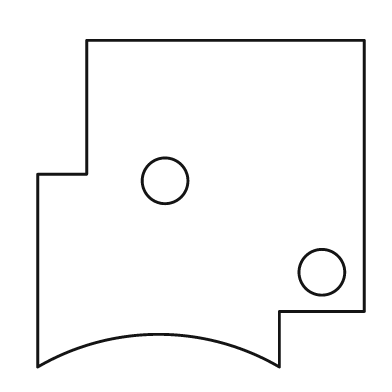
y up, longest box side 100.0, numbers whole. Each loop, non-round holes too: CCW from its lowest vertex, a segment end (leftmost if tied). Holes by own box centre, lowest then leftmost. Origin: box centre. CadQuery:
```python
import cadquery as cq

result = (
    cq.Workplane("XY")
    .moveTo(-50.0, -50.0)
    .threePointArc((-13.0, -40.0), (24.0, -50.0))
    .lineTo(24.0, -33.0)
    .lineTo(50.0, -33.0)
    .lineTo(50.0, 50.0)
    .lineTo(-35.0, 50.0)
    .lineTo(-35.0, 9.0)
    .lineTo(-50.0, 9.0)
    .close()
    .moveTo(37.0, -21.0)
    .circle(7.0)
    .moveTo(-11.0, 7.0)
    .circle(7.0)
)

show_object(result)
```